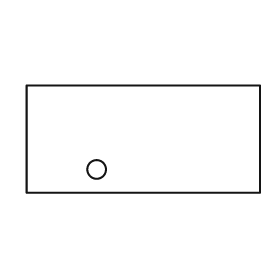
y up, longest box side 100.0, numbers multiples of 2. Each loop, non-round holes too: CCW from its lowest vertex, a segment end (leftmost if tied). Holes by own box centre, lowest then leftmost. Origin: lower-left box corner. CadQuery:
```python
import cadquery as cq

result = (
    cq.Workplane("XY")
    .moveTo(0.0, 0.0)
    .lineTo(100.0, 0.0)
    .lineTo(100.0, 46.0)
    .lineTo(0.0, 46.0)
    .close()
    .moveTo(30.0, 10.0)
    .circle(4.0)
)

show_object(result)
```